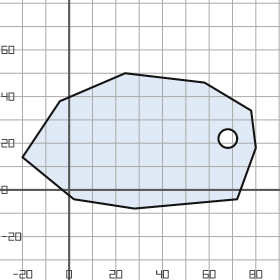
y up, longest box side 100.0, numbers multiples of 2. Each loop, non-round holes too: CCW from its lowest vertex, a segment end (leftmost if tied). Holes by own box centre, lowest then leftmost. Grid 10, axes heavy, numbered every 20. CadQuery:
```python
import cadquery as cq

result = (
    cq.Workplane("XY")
    .moveTo(28.0, -8.0)
    .lineTo(72.0, -4.0)
    .lineTo(80.0, 18.0)
    .lineTo(78.0, 34.0)
    .lineTo(58.0, 46.0)
    .lineTo(24.0, 50.0)
    .lineTo(-4.0, 38.0)
    .lineTo(-20.0, 14.0)
    .lineTo(2.0, -4.0)
    .close()
    .moveTo(68.0, 22.0)
    .circle(4.0)
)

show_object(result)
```